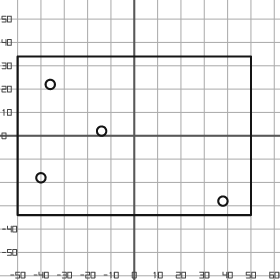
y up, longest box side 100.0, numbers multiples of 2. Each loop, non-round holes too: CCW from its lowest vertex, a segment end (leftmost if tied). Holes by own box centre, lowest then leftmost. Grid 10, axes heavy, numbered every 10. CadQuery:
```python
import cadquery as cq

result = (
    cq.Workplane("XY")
    .moveTo(-50.0, -34.0)
    .lineTo(50.0, -34.0)
    .lineTo(50.0, 34.0)
    .lineTo(-50.0, 34.0)
    .close()
    .moveTo(38.0, -28.0)
    .circle(2.0)
    .moveTo(-40.0, -18.0)
    .circle(2.0)
    .moveTo(-14.0, 2.0)
    .circle(2.0)
    .moveTo(-36.0, 22.0)
    .circle(2.0)
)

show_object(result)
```